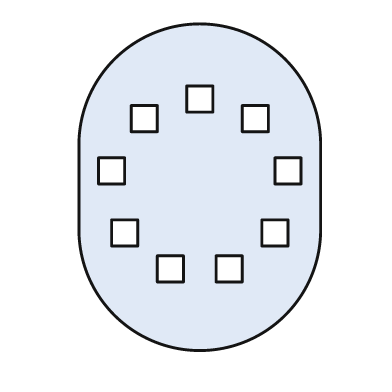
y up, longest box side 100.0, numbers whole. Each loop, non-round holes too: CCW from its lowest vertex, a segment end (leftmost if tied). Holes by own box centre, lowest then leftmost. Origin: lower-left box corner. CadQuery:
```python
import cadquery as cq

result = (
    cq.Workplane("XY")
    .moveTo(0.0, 37.0)
    .threePointArc((37.0, 0.0), (74.0, 37.0))
    .lineTo(74.0, 63.0)
    .threePointArc((37.0, 100.0), (0.0, 63.0))
    .close()
    .moveTo(24.0, 21.0)
    .lineTo(32.0, 21.0)
    .lineTo(32.0, 29.0)
    .lineTo(24.0, 29.0)
    .close()
    .moveTo(42.0, 21.0)
    .lineTo(50.0, 21.0)
    .lineTo(50.0, 29.0)
    .lineTo(42.0, 29.0)
    .close()
    .moveTo(10.0, 32.0)
    .lineTo(18.0, 32.0)
    .lineTo(18.0, 40.0)
    .lineTo(10.0, 40.0)
    .close()
    .moveTo(56.0, 32.0)
    .lineTo(64.0, 32.0)
    .lineTo(64.0, 40.0)
    .lineTo(56.0, 40.0)
    .close()
    .moveTo(6.0, 51.0)
    .lineTo(14.0, 51.0)
    .lineTo(14.0, 59.0)
    .lineTo(6.0, 59.0)
    .close()
    .moveTo(60.0, 51.0)
    .lineTo(68.0, 51.0)
    .lineTo(68.0, 59.0)
    .lineTo(60.0, 59.0)
    .close()
    .moveTo(16.0, 67.0)
    .lineTo(24.0, 67.0)
    .lineTo(24.0, 75.0)
    .lineTo(16.0, 75.0)
    .close()
    .moveTo(50.0, 67.0)
    .lineTo(58.0, 67.0)
    .lineTo(58.0, 75.0)
    .lineTo(50.0, 75.0)
    .close()
    .moveTo(33.0, 73.0)
    .lineTo(41.0, 73.0)
    .lineTo(41.0, 81.0)
    .lineTo(33.0, 81.0)
    .close()
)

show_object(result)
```